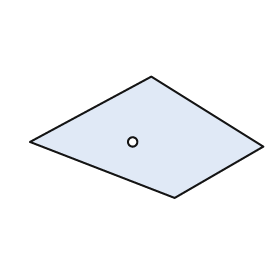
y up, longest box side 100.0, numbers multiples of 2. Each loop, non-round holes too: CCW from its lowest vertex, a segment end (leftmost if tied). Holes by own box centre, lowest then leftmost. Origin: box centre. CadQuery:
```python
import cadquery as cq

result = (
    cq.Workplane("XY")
    .moveTo(12.0, -26.0)
    .lineTo(50.0, -4.0)
    .lineTo(2.0, 26.0)
    .lineTo(-50.0, -2.0)
    .close()
    .moveTo(-6.0, -2.0)
    .circle(2.0)
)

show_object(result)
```